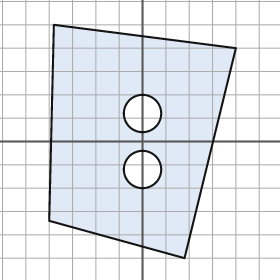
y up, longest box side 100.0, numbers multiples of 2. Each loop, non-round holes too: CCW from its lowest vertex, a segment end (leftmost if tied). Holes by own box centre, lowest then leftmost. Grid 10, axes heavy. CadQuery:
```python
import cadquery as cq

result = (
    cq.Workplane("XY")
    .moveTo(18.0, -50.0)
    .lineTo(40.0, 40.0)
    .lineTo(-38.0, 50.0)
    .lineTo(-40.0, -34.0)
    .close()
    .moveTo(0.0, -12.0)
    .circle(8.0)
    .moveTo(0.0, 12.0)
    .circle(8.0)
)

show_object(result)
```